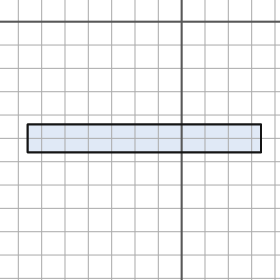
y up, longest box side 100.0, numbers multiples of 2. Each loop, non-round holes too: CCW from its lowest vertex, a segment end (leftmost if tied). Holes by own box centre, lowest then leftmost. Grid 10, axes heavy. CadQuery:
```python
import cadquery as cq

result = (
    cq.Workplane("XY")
    .moveTo(-66.0, -56.0)
    .lineTo(34.0, -56.0)
    .lineTo(34.0, -44.0)
    .lineTo(-66.0, -44.0)
    .close()
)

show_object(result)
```